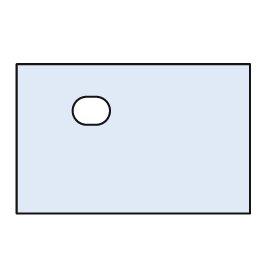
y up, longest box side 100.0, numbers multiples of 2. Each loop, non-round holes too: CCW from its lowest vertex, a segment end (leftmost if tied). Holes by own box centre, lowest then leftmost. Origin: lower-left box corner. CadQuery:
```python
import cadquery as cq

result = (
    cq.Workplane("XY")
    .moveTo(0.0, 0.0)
    .lineTo(100.0, 0.0)
    .lineTo(100.0, 64.0)
    .lineTo(0.0, 64.0)
    .close()
    .moveTo(30.0, 38.0)
    .lineTo(34.0, 38.0)
    .threePointArc((40.0, 44.0), (34.0, 50.0))
    .lineTo(30.0, 50.0)
    .threePointArc((24.0, 44.0), (30.0, 38.0))
    .close()
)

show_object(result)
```